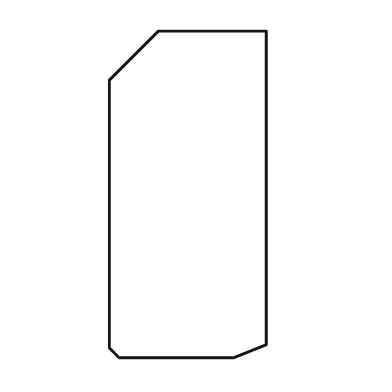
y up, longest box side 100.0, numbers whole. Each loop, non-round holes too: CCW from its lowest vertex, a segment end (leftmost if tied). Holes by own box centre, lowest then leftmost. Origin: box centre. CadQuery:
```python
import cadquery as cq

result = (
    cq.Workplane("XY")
    .moveTo(-21.0, -50.0)
    .lineTo(14.0, -50.0)
    .lineTo(24.0, -46.0)
    .lineTo(24.0, 50.0)
    .lineTo(-9.0, 50.0)
    .lineTo(-24.0, 35.0)
    .lineTo(-24.0, -47.0)
    .close()
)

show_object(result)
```